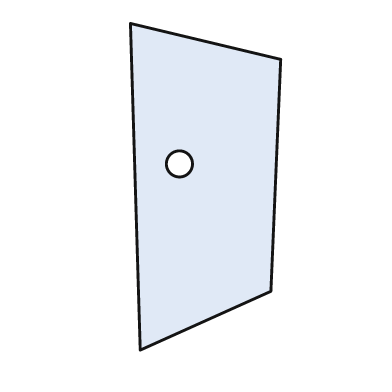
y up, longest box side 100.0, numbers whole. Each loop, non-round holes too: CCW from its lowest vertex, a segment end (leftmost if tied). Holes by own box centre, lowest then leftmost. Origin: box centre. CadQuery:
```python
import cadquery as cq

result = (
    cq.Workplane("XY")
    .moveTo(-20.0, -50.0)
    .lineTo(20.0, -32.0)
    .lineTo(23.0, 39.0)
    .lineTo(-23.0, 50.0)
    .close()
    .moveTo(-8.0, 7.0)
    .circle(4.0)
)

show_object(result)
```